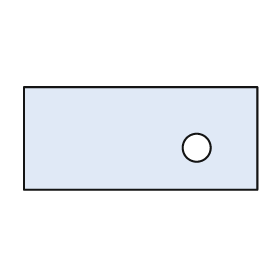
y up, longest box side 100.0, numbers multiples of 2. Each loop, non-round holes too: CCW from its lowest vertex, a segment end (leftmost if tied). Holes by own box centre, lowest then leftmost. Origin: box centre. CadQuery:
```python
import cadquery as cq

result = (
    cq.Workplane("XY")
    .moveTo(-50.0, -22.0)
    .lineTo(50.0, -22.0)
    .lineTo(50.0, 22.0)
    .lineTo(-50.0, 22.0)
    .close()
    .moveTo(24.0, -4.0)
    .circle(6.0)
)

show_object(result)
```